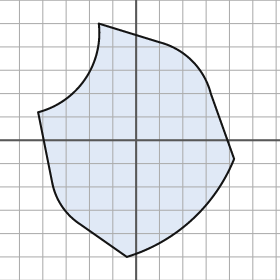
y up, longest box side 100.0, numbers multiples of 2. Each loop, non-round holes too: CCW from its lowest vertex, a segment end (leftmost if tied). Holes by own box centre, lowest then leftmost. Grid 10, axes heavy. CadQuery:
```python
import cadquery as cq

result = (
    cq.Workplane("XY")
    .moveTo(-4.0, -50.0)
    .threePointArc((24.0, -34.0), (42.0, -8.0))
    .lineTo(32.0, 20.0)
    .threePointArc((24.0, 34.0), (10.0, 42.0))
    .lineTo(-16.0, 50.0)
    .threePointArc((-22.0, 26.0), (-42.0, 12.0))
    .lineTo(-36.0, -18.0)
    .threePointArc((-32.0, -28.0), (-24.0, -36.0))
    .close()
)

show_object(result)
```